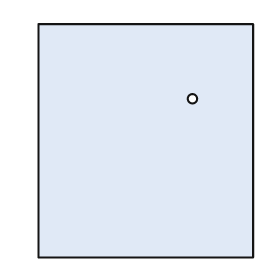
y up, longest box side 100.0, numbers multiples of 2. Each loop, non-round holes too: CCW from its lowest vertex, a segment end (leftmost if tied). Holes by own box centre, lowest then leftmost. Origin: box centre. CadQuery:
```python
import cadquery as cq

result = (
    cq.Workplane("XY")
    .moveTo(-46.0, -50.0)
    .lineTo(46.0, -50.0)
    .lineTo(46.0, 50.0)
    .lineTo(-46.0, 50.0)
    .close()
    .moveTo(20.0, 18.0)
    .circle(2.0)
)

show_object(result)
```